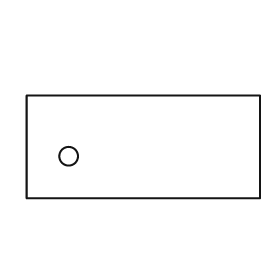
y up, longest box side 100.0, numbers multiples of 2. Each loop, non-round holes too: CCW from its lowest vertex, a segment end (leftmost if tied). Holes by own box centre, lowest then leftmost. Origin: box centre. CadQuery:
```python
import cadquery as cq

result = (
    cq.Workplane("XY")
    .moveTo(-50.0, -22.0)
    .lineTo(50.0, -22.0)
    .lineTo(50.0, 22.0)
    .lineTo(-50.0, 22.0)
    .close()
    .moveTo(-32.0, -4.0)
    .circle(4.0)
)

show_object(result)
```